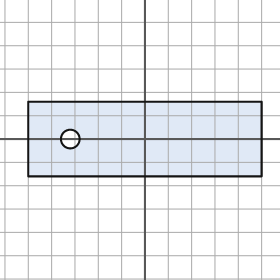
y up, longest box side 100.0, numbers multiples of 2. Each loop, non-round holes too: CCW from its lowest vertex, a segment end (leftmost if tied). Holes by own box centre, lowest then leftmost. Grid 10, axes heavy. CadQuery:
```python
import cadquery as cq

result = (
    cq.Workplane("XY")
    .moveTo(-50.0, -16.0)
    .lineTo(50.0, -16.0)
    .lineTo(50.0, 16.0)
    .lineTo(-50.0, 16.0)
    .close()
    .moveTo(-32.0, 0.0)
    .circle(4.0)
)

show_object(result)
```